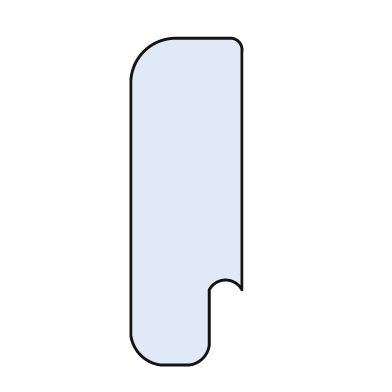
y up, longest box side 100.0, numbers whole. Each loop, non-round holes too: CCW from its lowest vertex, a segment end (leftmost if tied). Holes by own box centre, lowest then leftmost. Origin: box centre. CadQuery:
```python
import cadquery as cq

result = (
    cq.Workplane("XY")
    .moveTo(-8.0, -50.0)
    .lineTo(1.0, -50.0)
    .threePointArc((5.0, -48.0), (7.0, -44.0))
    .lineTo(7.0, -27.0)
    .threePointArc((12.0, -24.0), (17.0, -27.0))
    .lineTo(17.0, 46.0)
    .threePointArc((16.0, 49.0), (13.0, 50.0))
    .lineTo(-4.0, 50.0)
    .threePointArc((-13.0, 46.0), (-17.0, 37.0))
    .lineTo(-17.0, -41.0)
    .threePointArc((-14.0, -47.0), (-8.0, -50.0))
    .close()
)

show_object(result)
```